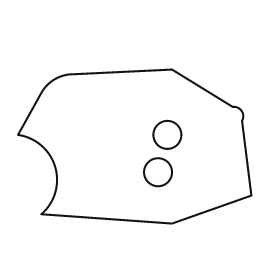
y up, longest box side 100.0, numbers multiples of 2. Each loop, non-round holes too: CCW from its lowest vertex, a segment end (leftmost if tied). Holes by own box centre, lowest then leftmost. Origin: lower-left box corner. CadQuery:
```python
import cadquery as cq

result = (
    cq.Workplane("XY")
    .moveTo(66.0, 0.0)
    .lineTo(100.0, 12.0)
    .lineTo(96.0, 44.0)
    .threePointArc((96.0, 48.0), (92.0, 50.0))
    .lineTo(66.0, 66.0)
    .lineTo(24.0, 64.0)
    .threePointArc((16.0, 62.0), (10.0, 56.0))
    .lineTo(0.0, 38.0)
    .threePointArc((16.0, 24.0), (10.0, 4.0))
    .close()
    .moveTo(60.0, 22.0)
    .circle(6.0)
    .moveTo(64.0, 38.0)
    .circle(6.0)
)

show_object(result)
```